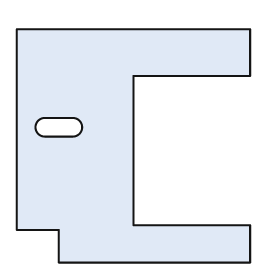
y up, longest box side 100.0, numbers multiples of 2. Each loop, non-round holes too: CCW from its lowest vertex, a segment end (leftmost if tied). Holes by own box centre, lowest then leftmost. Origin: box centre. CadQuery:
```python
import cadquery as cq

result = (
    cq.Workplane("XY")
    .moveTo(-32.0, -50.0)
    .lineTo(50.0, -50.0)
    .lineTo(50.0, -34.0)
    .lineTo(0.0, -34.0)
    .lineTo(0.0, 30.0)
    .lineTo(50.0, 30.0)
    .lineTo(50.0, 50.0)
    .lineTo(-50.0, 50.0)
    .lineTo(-50.0, -36.0)
    .lineTo(-32.0, -36.0)
    .close()
    .moveTo(-38.0, 4.0)
    .lineTo(-26.0, 4.0)
    .threePointArc((-22.0, 8.0), (-26.0, 12.0))
    .lineTo(-38.0, 12.0)
    .threePointArc((-42.0, 8.0), (-38.0, 4.0))
    .close()
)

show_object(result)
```